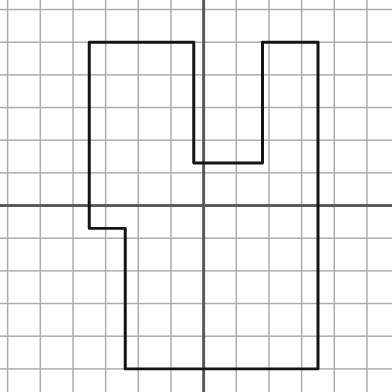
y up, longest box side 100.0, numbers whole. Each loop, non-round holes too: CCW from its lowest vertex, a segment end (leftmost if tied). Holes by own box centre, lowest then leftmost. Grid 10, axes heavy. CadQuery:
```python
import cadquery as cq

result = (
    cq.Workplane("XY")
    .moveTo(-24.0, -50.0)
    .lineTo(35.0, -50.0)
    .lineTo(35.0, 50.0)
    .lineTo(18.0, 50.0)
    .lineTo(18.0, 13.0)
    .lineTo(-3.0, 13.0)
    .lineTo(-3.0, 50.0)
    .lineTo(-35.0, 50.0)
    .lineTo(-35.0, -7.0)
    .lineTo(-24.0, -7.0)
    .close()
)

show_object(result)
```